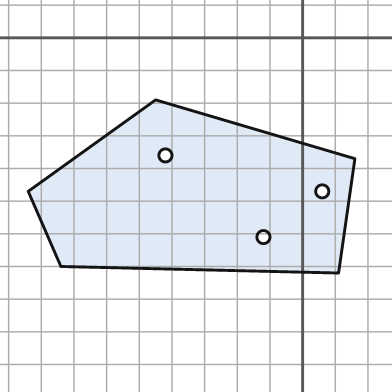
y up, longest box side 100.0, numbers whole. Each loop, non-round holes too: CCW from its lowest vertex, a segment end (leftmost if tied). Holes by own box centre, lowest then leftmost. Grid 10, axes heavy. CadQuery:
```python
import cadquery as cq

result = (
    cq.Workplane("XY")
    .moveTo(11.0, -72.0)
    .lineTo(16.0, -37.0)
    .lineTo(-45.0, -19.0)
    .lineTo(-84.0, -47.0)
    .lineTo(-74.0, -70.0)
    .close()
    .moveTo(-12.0, -61.0)
    .circle(2.0)
    .moveTo(6.0, -47.0)
    .circle(2.0)
    .moveTo(-42.0, -36.0)
    .circle(2.0)
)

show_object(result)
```